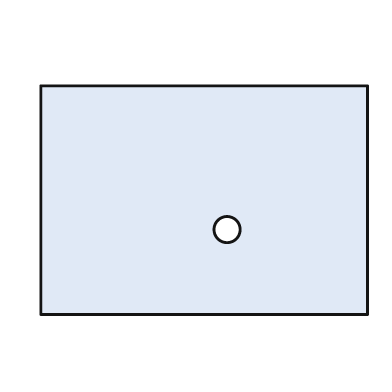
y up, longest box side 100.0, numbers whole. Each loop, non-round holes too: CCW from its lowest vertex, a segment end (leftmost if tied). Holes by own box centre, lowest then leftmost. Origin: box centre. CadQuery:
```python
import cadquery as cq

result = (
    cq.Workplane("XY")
    .moveTo(-50.0, -35.0)
    .lineTo(50.0, -35.0)
    .lineTo(50.0, 35.0)
    .lineTo(-50.0, 35.0)
    .close()
    .moveTo(7.0, -9.0)
    .circle(4.0)
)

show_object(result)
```